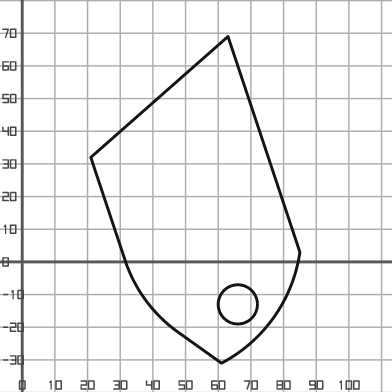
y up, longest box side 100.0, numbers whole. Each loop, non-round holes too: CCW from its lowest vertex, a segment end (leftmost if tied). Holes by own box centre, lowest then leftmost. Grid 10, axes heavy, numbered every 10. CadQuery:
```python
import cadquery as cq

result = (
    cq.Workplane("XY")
    .moveTo(61.0, -31.0)
    .threePointArc((77.0, -17.0), (85.0, 3.0))
    .lineTo(63.0, 69.0)
    .lineTo(21.0, 32.0)
    .lineTo(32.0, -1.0)
    .threePointArc((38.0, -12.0), (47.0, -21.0))
    .close()
    .moveTo(66.0, -13.0)
    .circle(6.0)
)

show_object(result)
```